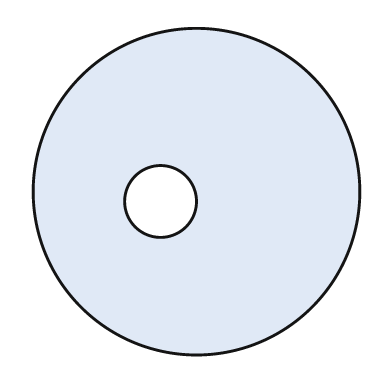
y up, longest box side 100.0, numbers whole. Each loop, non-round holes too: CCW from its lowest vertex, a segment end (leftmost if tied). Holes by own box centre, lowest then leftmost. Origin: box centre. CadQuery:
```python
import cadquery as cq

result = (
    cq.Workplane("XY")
    .moveTo(0.0, 0.0)
    .circle(50.0)
    .moveTo(-11.0, -3.0)
    .circle(11.0)
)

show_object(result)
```